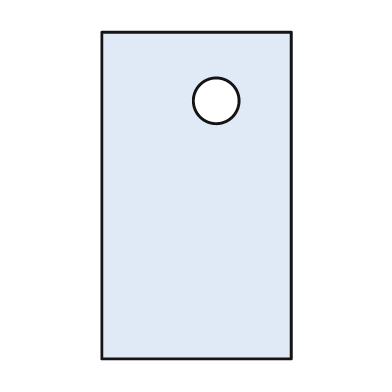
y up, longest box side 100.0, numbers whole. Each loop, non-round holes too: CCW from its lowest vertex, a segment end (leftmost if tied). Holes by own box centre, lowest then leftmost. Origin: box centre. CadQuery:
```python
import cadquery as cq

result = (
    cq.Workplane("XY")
    .moveTo(-29.0, -50.0)
    .lineTo(29.0, -50.0)
    .lineTo(29.0, 50.0)
    .lineTo(-29.0, 50.0)
    .close()
    .moveTo(6.0, 29.0)
    .circle(7.0)
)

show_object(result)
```